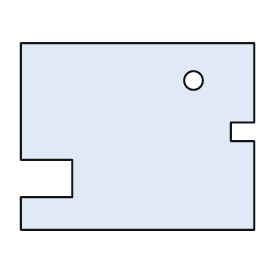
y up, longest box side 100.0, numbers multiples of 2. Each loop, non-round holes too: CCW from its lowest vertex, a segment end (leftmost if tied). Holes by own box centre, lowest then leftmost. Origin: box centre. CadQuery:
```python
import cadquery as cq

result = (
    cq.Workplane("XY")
    .moveTo(-50.0, -40.0)
    .lineTo(50.0, -40.0)
    .lineTo(50.0, -2.0)
    .lineTo(40.0, -2.0)
    .lineTo(40.0, 6.0)
    .lineTo(50.0, 6.0)
    .lineTo(50.0, 40.0)
    .lineTo(-50.0, 40.0)
    .lineTo(-50.0, -10.0)
    .lineTo(-28.0, -10.0)
    .lineTo(-28.0, -26.0)
    .lineTo(-50.0, -26.0)
    .close()
    .moveTo(24.0, 24.0)
    .circle(4.0)
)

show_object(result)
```